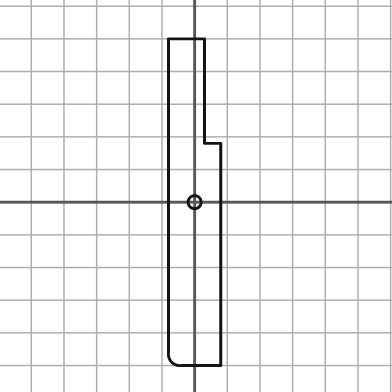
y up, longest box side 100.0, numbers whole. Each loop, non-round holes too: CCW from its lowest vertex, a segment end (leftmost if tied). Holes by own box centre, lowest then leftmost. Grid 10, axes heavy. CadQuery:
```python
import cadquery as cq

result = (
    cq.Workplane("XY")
    .moveTo(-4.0, -50.0)
    .lineTo(8.0, -50.0)
    .lineTo(8.0, 18.0)
    .lineTo(3.0, 18.0)
    .lineTo(3.0, 50.0)
    .lineTo(-8.0, 50.0)
    .lineTo(-8.0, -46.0)
    .threePointArc((-7.0, -49.0), (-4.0, -50.0))
    .close()
    .moveTo(0.0, 0.0)
    .circle(2.0)
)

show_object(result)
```